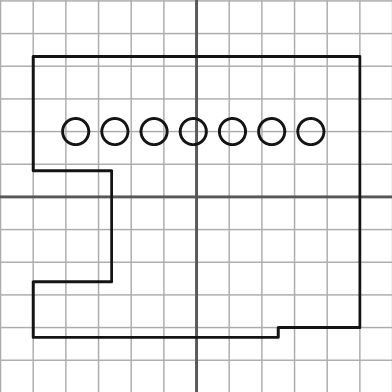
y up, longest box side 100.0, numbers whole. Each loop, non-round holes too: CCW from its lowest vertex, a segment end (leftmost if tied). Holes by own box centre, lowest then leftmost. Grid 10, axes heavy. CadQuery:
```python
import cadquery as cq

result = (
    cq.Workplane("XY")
    .moveTo(-50.0, -43.0)
    .lineTo(25.0, -43.0)
    .lineTo(25.0, -40.0)
    .lineTo(50.0, -40.0)
    .lineTo(50.0, 43.0)
    .lineTo(-50.0, 43.0)
    .lineTo(-50.0, 8.0)
    .lineTo(-26.0, 8.0)
    .lineTo(-26.0, -26.0)
    .lineTo(-50.0, -26.0)
    .close()
    .moveTo(-37.0, 20.0)
    .circle(4.0)
    .moveTo(-25.0, 20.0)
    .circle(4.0)
    .moveTo(-13.0, 20.0)
    .circle(4.0)
    .moveTo(-1.0, 20.0)
    .circle(4.0)
    .moveTo(11.0, 20.0)
    .circle(4.0)
    .moveTo(23.0, 20.0)
    .circle(4.0)
    .moveTo(35.0, 20.0)
    .circle(4.0)
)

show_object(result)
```